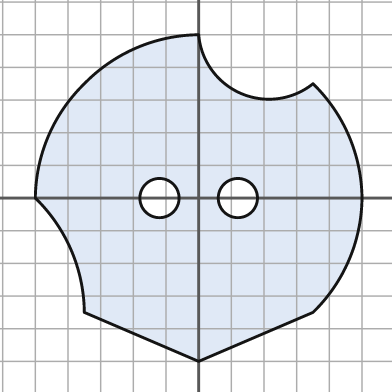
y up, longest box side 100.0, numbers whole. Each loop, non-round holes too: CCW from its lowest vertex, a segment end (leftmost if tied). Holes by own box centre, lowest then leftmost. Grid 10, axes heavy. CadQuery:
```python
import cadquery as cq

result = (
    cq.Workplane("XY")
    .moveTo(0.0, -50.0)
    .lineTo(35.0, -35.0)
    .threePointArc((46.0, -19.0), (50.0, 0.0))
    .threePointArc((46.0, 19.0), (35.0, 35.0))
    .threePointArc((13.0, 32.0), (0.0, 50.0))
    .threePointArc((-19.0, 46.0), (-35.0, 35.0))
    .threePointArc((-46.0, 19.0), (-50.0, 0.0))
    .threePointArc((-39.0, -16.0), (-35.0, -35.0))
    .close()
    .moveTo(-12.0, 0.0)
    .circle(6.0)
    .moveTo(12.0, 0.0)
    .circle(6.0)
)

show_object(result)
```